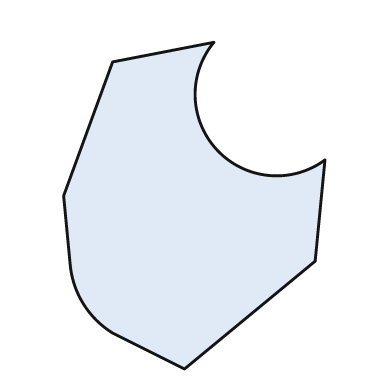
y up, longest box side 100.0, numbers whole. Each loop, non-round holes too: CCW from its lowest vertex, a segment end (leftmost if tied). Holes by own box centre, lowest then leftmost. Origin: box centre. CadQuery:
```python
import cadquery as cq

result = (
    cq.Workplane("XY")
    .moveTo(-3.0, -50.0)
    .lineTo(37.0, -17.0)
    .lineTo(40.0, 14.0)
    .threePointArc((7.0, 17.0), (6.0, 50.0))
    .lineTo(-25.0, 44.0)
    .lineTo(-40.0, 3.0)
    .lineTo(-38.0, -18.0)
    .threePointArc((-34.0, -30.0), (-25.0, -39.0))
    .close()
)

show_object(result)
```